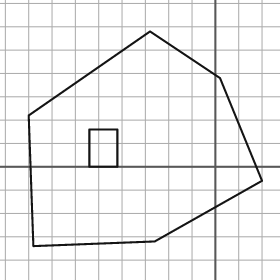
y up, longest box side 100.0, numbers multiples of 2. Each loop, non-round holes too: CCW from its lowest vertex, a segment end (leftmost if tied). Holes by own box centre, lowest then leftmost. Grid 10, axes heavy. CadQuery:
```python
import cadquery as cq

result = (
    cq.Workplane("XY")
    .moveTo(-78.0, -34.0)
    .lineTo(-26.0, -32.0)
    .lineTo(20.0, -6.0)
    .lineTo(2.0, 38.0)
    .lineTo(-28.0, 58.0)
    .lineTo(-80.0, 22.0)
    .close()
    .moveTo(-54.0, 0.0)
    .lineTo(-42.0, 0.0)
    .lineTo(-42.0, 16.0)
    .lineTo(-54.0, 16.0)
    .close()
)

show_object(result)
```